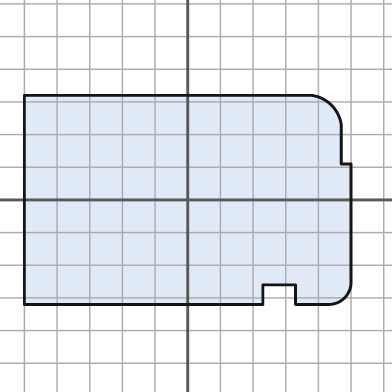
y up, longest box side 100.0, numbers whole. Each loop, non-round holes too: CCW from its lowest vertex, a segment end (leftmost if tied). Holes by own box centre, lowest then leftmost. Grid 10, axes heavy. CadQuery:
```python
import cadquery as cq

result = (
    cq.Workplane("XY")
    .moveTo(-50.0, -32.0)
    .lineTo(23.0, -32.0)
    .lineTo(23.0, -26.0)
    .lineTo(33.0, -26.0)
    .lineTo(33.0, -32.0)
    .lineTo(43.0, -32.0)
    .threePointArc((48.0, -30.0), (50.0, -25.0))
    .lineTo(50.0, 11.0)
    .lineTo(47.0, 11.0)
    .lineTo(47.0, 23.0)
    .threePointArc((44.0, 29.0), (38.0, 32.0))
    .lineTo(-50.0, 32.0)
    .close()
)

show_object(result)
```